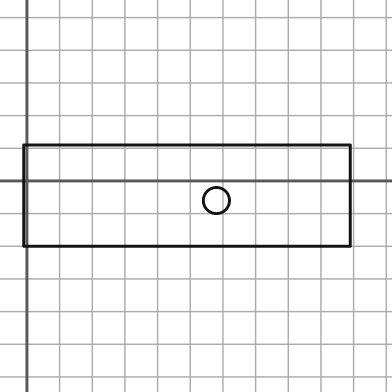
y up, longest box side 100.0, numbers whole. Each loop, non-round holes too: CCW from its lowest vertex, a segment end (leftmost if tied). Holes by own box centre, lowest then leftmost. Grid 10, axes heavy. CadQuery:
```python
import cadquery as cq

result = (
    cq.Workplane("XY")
    .moveTo(-1.0, -20.0)
    .lineTo(99.0, -20.0)
    .lineTo(99.0, 11.0)
    .lineTo(-1.0, 11.0)
    .close()
    .moveTo(58.0, -6.0)
    .circle(4.0)
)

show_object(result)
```